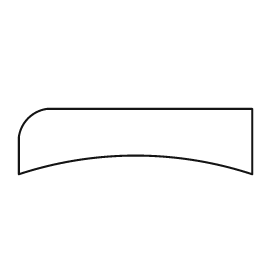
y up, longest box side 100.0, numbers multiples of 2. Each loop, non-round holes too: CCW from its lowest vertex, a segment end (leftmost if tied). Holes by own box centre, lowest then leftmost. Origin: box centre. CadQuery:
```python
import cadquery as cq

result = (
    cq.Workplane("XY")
    .moveTo(-50.0, -14.0)
    .threePointArc((0.0, -6.0), (50.0, -14.0))
    .lineTo(50.0, 14.0)
    .lineTo(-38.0, 14.0)
    .threePointArc((-46.0, 10.0), (-50.0, 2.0))
    .close()
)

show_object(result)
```